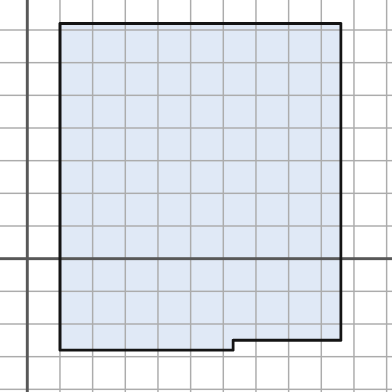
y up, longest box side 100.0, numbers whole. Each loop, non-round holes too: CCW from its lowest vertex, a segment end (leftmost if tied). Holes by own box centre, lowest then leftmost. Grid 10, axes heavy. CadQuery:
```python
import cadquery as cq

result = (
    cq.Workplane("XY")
    .moveTo(10.0, -28.0)
    .lineTo(63.0, -28.0)
    .lineTo(63.0, -25.0)
    .lineTo(96.0, -25.0)
    .lineTo(96.0, 72.0)
    .lineTo(10.0, 72.0)
    .close()
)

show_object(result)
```